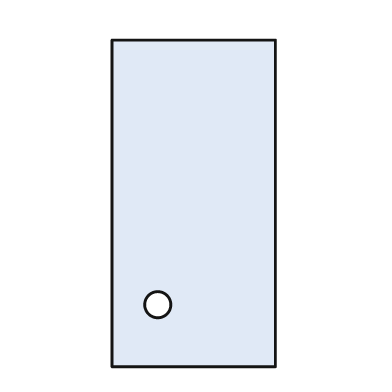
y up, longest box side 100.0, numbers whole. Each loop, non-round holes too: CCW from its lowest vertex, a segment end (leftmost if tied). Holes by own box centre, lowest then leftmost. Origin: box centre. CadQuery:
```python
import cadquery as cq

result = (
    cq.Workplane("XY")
    .moveTo(-25.0, -50.0)
    .lineTo(25.0, -50.0)
    .lineTo(25.0, 50.0)
    .lineTo(-25.0, 50.0)
    .close()
    .moveTo(-11.0, -31.0)
    .circle(4.0)
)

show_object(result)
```